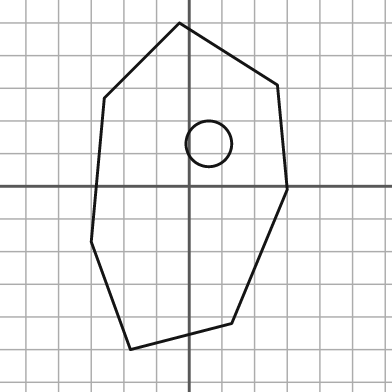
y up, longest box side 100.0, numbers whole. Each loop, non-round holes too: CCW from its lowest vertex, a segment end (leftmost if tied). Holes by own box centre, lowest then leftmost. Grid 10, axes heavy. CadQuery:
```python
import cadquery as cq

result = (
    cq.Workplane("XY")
    .moveTo(-18.0, -50.0)
    .lineTo(13.0, -42.0)
    .lineTo(30.0, -1.0)
    .lineTo(27.0, 31.0)
    .lineTo(-3.0, 50.0)
    .lineTo(-26.0, 27.0)
    .lineTo(-30.0, -17.0)
    .close()
    .moveTo(6.0, 13.0)
    .circle(7.0)
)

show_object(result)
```